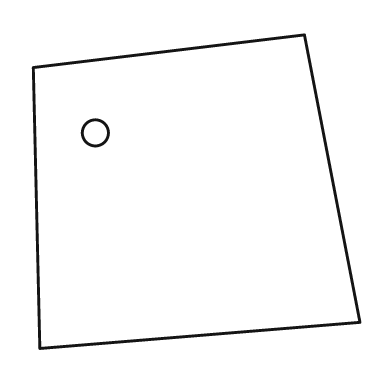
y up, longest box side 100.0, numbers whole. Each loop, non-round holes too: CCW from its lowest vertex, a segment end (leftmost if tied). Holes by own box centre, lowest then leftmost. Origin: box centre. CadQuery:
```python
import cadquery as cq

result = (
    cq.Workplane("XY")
    .moveTo(-48.0, -48.0)
    .lineTo(50.0, -40.0)
    .lineTo(33.0, 48.0)
    .lineTo(-50.0, 38.0)
    .close()
    .moveTo(-31.0, 18.0)
    .circle(4.0)
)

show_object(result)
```